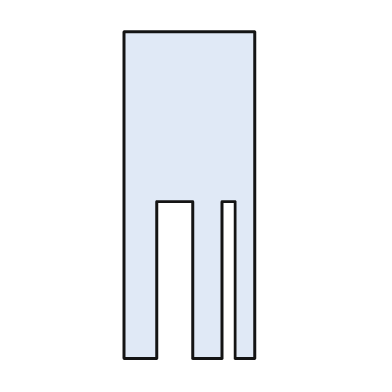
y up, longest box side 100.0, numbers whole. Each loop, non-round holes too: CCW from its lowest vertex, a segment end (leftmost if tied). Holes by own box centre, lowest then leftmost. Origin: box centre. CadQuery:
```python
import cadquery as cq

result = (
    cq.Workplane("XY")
    .moveTo(-20.0, -50.0)
    .lineTo(-10.0, -50.0)
    .lineTo(-10.0, -2.0)
    .lineTo(1.0, -2.0)
    .lineTo(1.0, -50.0)
    .lineTo(10.0, -50.0)
    .lineTo(10.0, -2.0)
    .lineTo(14.0, -2.0)
    .lineTo(14.0, -50.0)
    .lineTo(20.0, -50.0)
    .lineTo(20.0, 50.0)
    .lineTo(-20.0, 50.0)
    .close()
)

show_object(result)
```